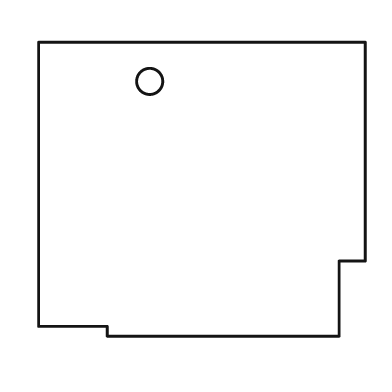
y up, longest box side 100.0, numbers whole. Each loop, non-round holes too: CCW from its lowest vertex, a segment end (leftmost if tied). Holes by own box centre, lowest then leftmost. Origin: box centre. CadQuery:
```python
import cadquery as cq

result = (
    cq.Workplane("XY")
    .moveTo(-29.0, -45.0)
    .lineTo(42.0, -45.0)
    .lineTo(42.0, -22.0)
    .lineTo(50.0, -22.0)
    .lineTo(50.0, 45.0)
    .lineTo(-50.0, 45.0)
    .lineTo(-50.0, -42.0)
    .lineTo(-29.0, -42.0)
    .close()
    .moveTo(-16.0, 33.0)
    .circle(4.0)
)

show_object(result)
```